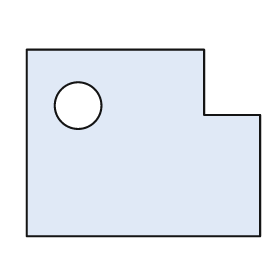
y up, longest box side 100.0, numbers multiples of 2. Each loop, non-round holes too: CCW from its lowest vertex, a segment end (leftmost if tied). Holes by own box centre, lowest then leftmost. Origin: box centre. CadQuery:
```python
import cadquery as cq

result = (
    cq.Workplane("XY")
    .moveTo(-50.0, -40.0)
    .lineTo(50.0, -40.0)
    .lineTo(50.0, 12.0)
    .lineTo(26.0, 12.0)
    .lineTo(26.0, 40.0)
    .lineTo(-50.0, 40.0)
    .close()
    .moveTo(-28.0, 16.0)
    .circle(10.0)
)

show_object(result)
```